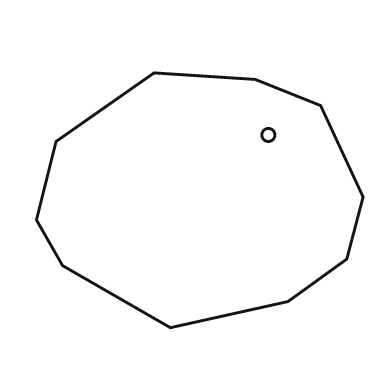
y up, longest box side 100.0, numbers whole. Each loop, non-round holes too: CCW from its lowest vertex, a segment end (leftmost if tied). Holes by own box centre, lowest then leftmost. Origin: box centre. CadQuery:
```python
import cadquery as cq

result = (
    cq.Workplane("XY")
    .moveTo(-9.0, -39.0)
    .lineTo(27.0, -31.0)
    .lineTo(45.0, -18.0)
    .lineTo(50.0, 1.0)
    .lineTo(37.0, 29.0)
    .lineTo(17.0, 37.0)
    .lineTo(-14.0, 39.0)
    .lineTo(-44.0, 18.0)
    .lineTo(-50.0, -6.0)
    .lineTo(-42.0, -20.0)
    .close()
    .moveTo(21.0, 20.0)
    .circle(2.0)
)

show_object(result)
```